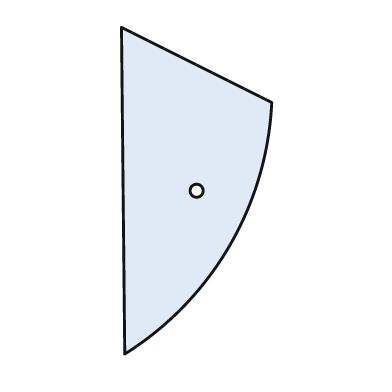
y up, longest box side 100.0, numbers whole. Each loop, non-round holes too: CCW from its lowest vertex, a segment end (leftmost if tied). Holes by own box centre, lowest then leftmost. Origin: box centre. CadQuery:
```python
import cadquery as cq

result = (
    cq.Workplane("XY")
    .moveTo(-22.0, -50.0)
    .threePointArc((10.0, -17.0), (23.0, 27.0))
    .lineTo(-23.0, 50.0)
    .close()
    .moveTo(0.0, 0.0)
    .circle(2.0)
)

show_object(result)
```